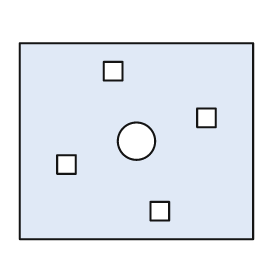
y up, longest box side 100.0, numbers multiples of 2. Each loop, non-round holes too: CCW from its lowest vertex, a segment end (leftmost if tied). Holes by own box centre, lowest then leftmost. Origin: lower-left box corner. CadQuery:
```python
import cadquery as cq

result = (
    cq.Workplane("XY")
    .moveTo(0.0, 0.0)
    .lineTo(100.0, 0.0)
    .lineTo(100.0, 84.0)
    .lineTo(0.0, 84.0)
    .close()
    .moveTo(56.0, 8.0)
    .lineTo(64.0, 8.0)
    .lineTo(64.0, 16.0)
    .lineTo(56.0, 16.0)
    .close()
    .moveTo(16.0, 28.0)
    .lineTo(24.0, 28.0)
    .lineTo(24.0, 36.0)
    .lineTo(16.0, 36.0)
    .close()
    .moveTo(50.0, 42.0)
    .circle(8.0)
    .moveTo(76.0, 48.0)
    .lineTo(84.0, 48.0)
    .lineTo(84.0, 56.0)
    .lineTo(76.0, 56.0)
    .close()
    .moveTo(36.0, 68.0)
    .lineTo(44.0, 68.0)
    .lineTo(44.0, 76.0)
    .lineTo(36.0, 76.0)
    .close()
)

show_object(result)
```